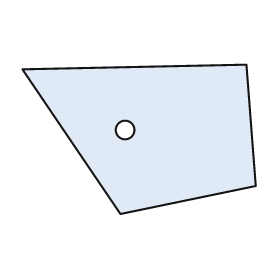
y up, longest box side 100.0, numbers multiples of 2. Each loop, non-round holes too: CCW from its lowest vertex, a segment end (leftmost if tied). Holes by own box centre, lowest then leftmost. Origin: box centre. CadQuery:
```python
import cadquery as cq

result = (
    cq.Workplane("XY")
    .moveTo(-8.0, -32.0)
    .lineTo(50.0, -20.0)
    .lineTo(46.0, 32.0)
    .lineTo(-50.0, 30.0)
    .close()
    .moveTo(-6.0, 4.0)
    .circle(4.0)
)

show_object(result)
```